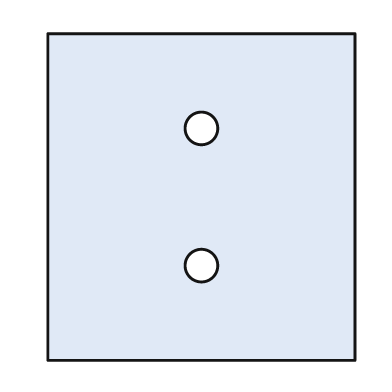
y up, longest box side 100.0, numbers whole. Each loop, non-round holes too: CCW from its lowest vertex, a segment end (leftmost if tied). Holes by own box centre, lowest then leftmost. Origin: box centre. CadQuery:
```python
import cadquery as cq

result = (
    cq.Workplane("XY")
    .moveTo(-47.0, -50.0)
    .lineTo(47.0, -50.0)
    .lineTo(47.0, 50.0)
    .lineTo(-47.0, 50.0)
    .close()
    .moveTo(0.0, -21.0)
    .circle(5.0)
    .moveTo(0.0, 21.0)
    .circle(5.0)
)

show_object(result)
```